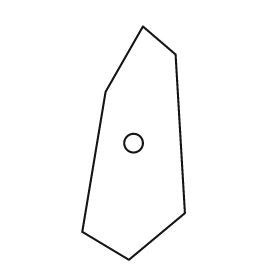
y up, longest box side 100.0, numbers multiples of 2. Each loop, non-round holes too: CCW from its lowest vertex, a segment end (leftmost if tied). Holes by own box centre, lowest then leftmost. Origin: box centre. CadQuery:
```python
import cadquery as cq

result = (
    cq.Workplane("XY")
    .moveTo(-2.0, -50.0)
    .lineTo(22.0, -30.0)
    .lineTo(18.0, 38.0)
    .lineTo(4.0, 50.0)
    .lineTo(-12.0, 22.0)
    .lineTo(-22.0, -38.0)
    .close()
    .moveTo(0.0, 0.0)
    .circle(4.0)
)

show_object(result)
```